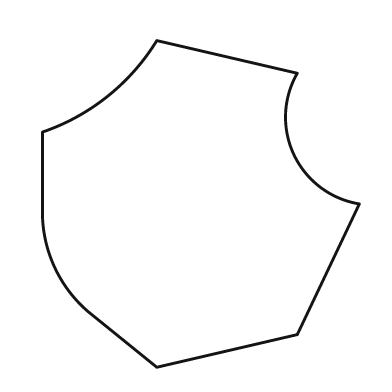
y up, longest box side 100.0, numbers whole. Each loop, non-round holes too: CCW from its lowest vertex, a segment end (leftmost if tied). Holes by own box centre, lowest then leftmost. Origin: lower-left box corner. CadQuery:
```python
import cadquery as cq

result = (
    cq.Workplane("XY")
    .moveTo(35.0, 0.0)
    .lineTo(78.0, 10.0)
    .lineTo(97.0, 50.0)
    .threePointArc((77.0, 65.0), (78.0, 90.0))
    .lineTo(35.0, 100.0)
    .threePointArc((20.0, 83.0), (0.0, 72.0))
    .lineTo(0.0, 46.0)
    .threePointArc((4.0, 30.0), (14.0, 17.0))
    .close()
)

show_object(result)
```